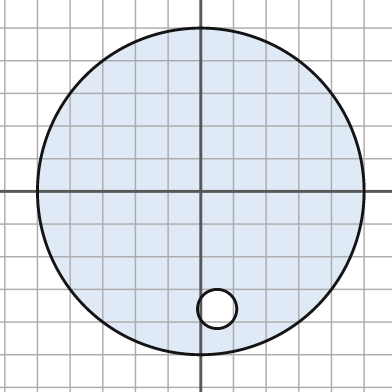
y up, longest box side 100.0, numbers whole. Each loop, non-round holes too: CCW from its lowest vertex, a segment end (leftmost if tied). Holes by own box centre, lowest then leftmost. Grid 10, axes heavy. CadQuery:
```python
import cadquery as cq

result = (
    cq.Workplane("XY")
    .moveTo(0.0, 0.0)
    .circle(50.0)
    .moveTo(5.0, -36.0)
    .circle(6.0)
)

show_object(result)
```